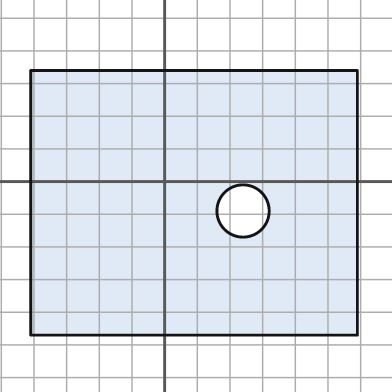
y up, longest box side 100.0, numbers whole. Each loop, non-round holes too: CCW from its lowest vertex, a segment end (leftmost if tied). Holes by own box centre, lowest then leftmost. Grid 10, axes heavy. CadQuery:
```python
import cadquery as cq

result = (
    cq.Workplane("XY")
    .moveTo(-41.0, -47.0)
    .lineTo(59.0, -47.0)
    .lineTo(59.0, 34.0)
    .lineTo(-41.0, 34.0)
    .close()
    .moveTo(24.0, -9.0)
    .circle(8.0)
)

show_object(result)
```